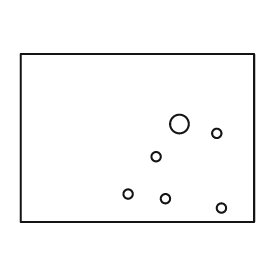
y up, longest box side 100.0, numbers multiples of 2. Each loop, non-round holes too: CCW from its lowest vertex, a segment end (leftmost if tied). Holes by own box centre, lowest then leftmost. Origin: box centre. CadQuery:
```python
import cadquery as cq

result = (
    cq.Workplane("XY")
    .moveTo(-50.0, -36.0)
    .lineTo(50.0, -36.0)
    .lineTo(50.0, 36.0)
    .lineTo(-50.0, 36.0)
    .close()
    .moveTo(36.0, -30.0)
    .circle(2.0)
    .moveTo(12.0, -26.0)
    .circle(2.0)
    .moveTo(-4.0, -24.0)
    .circle(2.0)
    .moveTo(8.0, -8.0)
    .circle(2.0)
    .moveTo(34.0, 2.0)
    .circle(2.0)
    .moveTo(18.0, 6.0)
    .circle(4.0)
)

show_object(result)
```